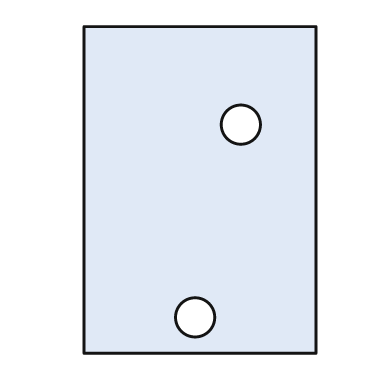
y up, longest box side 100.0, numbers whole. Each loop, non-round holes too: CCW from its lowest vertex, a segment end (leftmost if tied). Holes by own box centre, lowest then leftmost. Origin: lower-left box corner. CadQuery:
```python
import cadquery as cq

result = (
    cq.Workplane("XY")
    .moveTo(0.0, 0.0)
    .lineTo(71.0, 0.0)
    .lineTo(71.0, 100.0)
    .lineTo(0.0, 100.0)
    .close()
    .moveTo(34.0, 11.0)
    .circle(6.0)
    .moveTo(48.0, 70.0)
    .circle(6.0)
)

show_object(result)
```